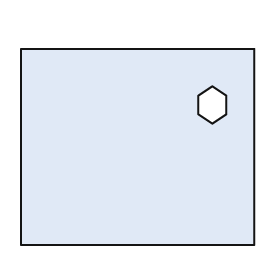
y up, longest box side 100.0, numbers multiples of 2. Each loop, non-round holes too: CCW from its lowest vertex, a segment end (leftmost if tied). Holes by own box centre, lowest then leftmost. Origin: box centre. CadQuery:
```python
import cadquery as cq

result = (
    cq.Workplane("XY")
    .moveTo(-50.0, -42.0)
    .lineTo(50.0, -42.0)
    .lineTo(50.0, 42.0)
    .lineTo(-50.0, 42.0)
    .close()
    .moveTo(32.0, 10.0)
    .lineTo(38.0, 14.0)
    .lineTo(38.0, 22.0)
    .lineTo(32.0, 26.0)
    .lineTo(26.0, 22.0)
    .lineTo(26.0, 14.0)
    .close()
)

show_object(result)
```